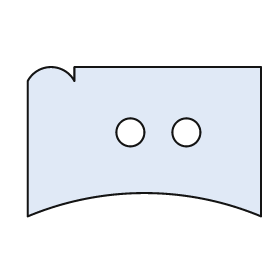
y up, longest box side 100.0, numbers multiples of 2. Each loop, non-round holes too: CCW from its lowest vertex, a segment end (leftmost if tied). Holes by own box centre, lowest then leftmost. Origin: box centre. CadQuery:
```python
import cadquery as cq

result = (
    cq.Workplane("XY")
    .moveTo(-50.0, -32.0)
    .threePointArc((0.0, -22.0), (50.0, -32.0))
    .lineTo(50.0, 32.0)
    .lineTo(-30.0, 32.0)
    .lineTo(-30.0, 26.0)
    .threePointArc((-40.0, 32.0), (-50.0, 26.0))
    .close()
    .moveTo(-6.0, 4.0)
    .circle(6.0)
    .moveTo(18.0, 4.0)
    .circle(6.0)
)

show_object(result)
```